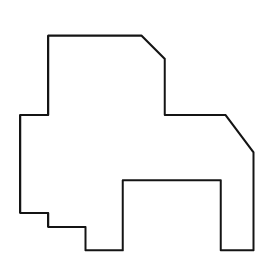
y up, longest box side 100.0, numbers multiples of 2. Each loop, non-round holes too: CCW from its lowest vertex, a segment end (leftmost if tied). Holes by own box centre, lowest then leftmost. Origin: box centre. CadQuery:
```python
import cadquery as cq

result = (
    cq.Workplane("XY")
    .moveTo(-22.0, -46.0)
    .lineTo(-6.0, -46.0)
    .lineTo(-6.0, -16.0)
    .lineTo(36.0, -16.0)
    .lineTo(36.0, -46.0)
    .lineTo(50.0, -46.0)
    .lineTo(50.0, -4.0)
    .lineTo(38.0, 12.0)
    .lineTo(12.0, 12.0)
    .lineTo(12.0, 36.0)
    .lineTo(2.0, 46.0)
    .lineTo(-38.0, 46.0)
    .lineTo(-38.0, 12.0)
    .lineTo(-50.0, 12.0)
    .lineTo(-50.0, -30.0)
    .lineTo(-38.0, -30.0)
    .lineTo(-38.0, -36.0)
    .lineTo(-22.0, -36.0)
    .close()
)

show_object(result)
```